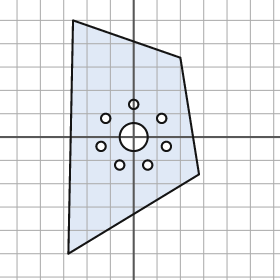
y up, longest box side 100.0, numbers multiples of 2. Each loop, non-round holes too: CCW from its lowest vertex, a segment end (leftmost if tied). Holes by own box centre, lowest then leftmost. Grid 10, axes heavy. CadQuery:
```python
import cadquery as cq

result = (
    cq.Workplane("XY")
    .moveTo(-28.0, -50.0)
    .lineTo(28.0, -16.0)
    .lineTo(20.0, 34.0)
    .lineTo(-26.0, 50.0)
    .close()
    .moveTo(-6.0, -12.0)
    .circle(2.0)
    .moveTo(6.0, -12.0)
    .circle(2.0)
    .moveTo(-14.0, -4.0)
    .circle(2.0)
    .moveTo(14.0, -4.0)
    .circle(2.0)
    .moveTo(0.0, 0.0)
    .circle(6.0)
    .moveTo(-12.0, 8.0)
    .circle(2.0)
    .moveTo(12.0, 8.0)
    .circle(2.0)
    .moveTo(0.0, 14.0)
    .circle(2.0)
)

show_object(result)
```